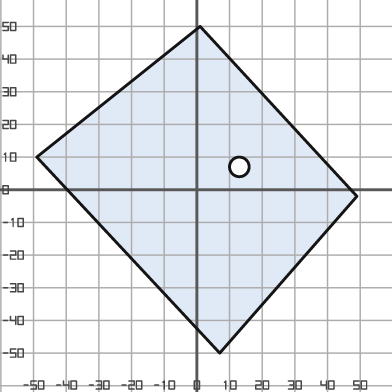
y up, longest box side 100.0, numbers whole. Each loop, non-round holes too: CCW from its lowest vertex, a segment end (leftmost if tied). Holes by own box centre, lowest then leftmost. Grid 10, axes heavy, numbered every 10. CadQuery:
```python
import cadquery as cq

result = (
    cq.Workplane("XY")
    .moveTo(7.0, -50.0)
    .lineTo(49.0, -2.0)
    .lineTo(1.0, 50.0)
    .lineTo(-49.0, 10.0)
    .close()
    .moveTo(13.0, 7.0)
    .circle(3.0)
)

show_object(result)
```